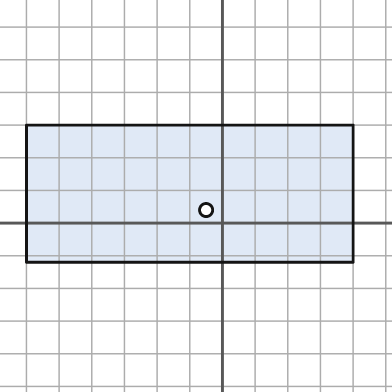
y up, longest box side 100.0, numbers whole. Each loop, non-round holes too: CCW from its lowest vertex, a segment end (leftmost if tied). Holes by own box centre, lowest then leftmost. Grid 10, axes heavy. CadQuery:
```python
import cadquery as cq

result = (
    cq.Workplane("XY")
    .moveTo(-60.0, -12.0)
    .lineTo(40.0, -12.0)
    .lineTo(40.0, 30.0)
    .lineTo(-60.0, 30.0)
    .close()
    .moveTo(-5.0, 4.0)
    .circle(2.0)
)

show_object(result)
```